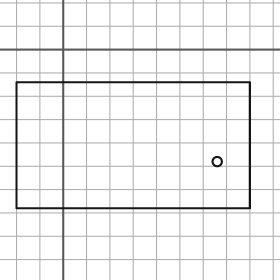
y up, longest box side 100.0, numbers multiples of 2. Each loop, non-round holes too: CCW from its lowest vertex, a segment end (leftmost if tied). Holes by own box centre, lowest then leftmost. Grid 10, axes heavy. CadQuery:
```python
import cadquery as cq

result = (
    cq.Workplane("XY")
    .moveTo(-20.0, -68.0)
    .lineTo(80.0, -68.0)
    .lineTo(80.0, -14.0)
    .lineTo(-20.0, -14.0)
    .close()
    .moveTo(66.0, -48.0)
    .circle(2.0)
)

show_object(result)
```